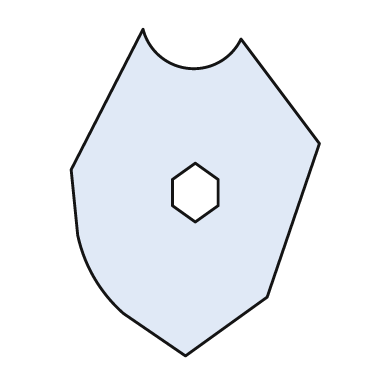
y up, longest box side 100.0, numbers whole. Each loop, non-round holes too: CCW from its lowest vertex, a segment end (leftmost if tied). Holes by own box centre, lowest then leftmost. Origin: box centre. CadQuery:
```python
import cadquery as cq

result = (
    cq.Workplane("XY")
    .moveTo(-3.0, -50.0)
    .lineTo(22.0, -32.0)
    .lineTo(38.0, 15.0)
    .lineTo(14.0, 47.0)
    .threePointArc((-2.0, 38.0), (-16.0, 50.0))
    .lineTo(-38.0, 7.0)
    .lineTo(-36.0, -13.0)
    .threePointArc((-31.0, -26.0), (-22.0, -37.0))
    .close()
    .moveTo(0.0, -9.0)
    .lineTo(7.0, -4.0)
    .lineTo(7.0, 4.0)
    .lineTo(0.0, 9.0)
    .lineTo(-7.0, 4.0)
    .lineTo(-7.0, -4.0)
    .close()
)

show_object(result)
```